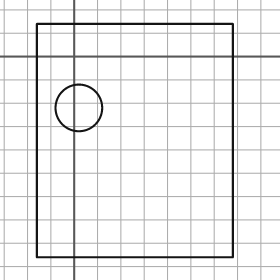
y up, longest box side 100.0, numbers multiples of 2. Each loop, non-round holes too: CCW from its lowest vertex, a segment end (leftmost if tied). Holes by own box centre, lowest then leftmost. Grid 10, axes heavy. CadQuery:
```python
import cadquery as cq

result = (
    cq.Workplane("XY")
    .moveTo(-16.0, -86.0)
    .lineTo(68.0, -86.0)
    .lineTo(68.0, 14.0)
    .lineTo(-16.0, 14.0)
    .close()
    .moveTo(2.0, -22.0)
    .circle(10.0)
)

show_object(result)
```